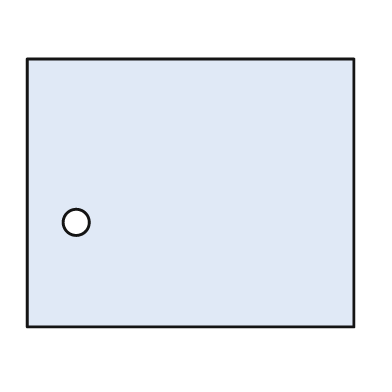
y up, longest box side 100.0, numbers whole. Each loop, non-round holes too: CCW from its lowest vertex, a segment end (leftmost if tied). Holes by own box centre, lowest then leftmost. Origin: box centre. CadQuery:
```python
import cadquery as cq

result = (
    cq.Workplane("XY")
    .moveTo(-50.0, -41.0)
    .lineTo(50.0, -41.0)
    .lineTo(50.0, 41.0)
    .lineTo(-50.0, 41.0)
    .close()
    .moveTo(-35.0, -9.0)
    .circle(4.0)
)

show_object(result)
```